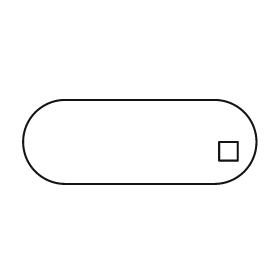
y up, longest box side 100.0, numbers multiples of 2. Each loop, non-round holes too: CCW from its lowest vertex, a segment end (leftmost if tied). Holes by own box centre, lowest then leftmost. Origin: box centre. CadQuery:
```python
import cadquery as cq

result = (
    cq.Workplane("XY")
    .moveTo(-32.0, -18.0)
    .lineTo(32.0, -18.0)
    .threePointArc((50.0, 0.0), (32.0, 18.0))
    .lineTo(-32.0, 18.0)
    .threePointArc((-50.0, 0.0), (-32.0, -18.0))
    .close()
    .moveTo(34.0, -8.0)
    .lineTo(42.0, -8.0)
    .lineTo(42.0, 0.0)
    .lineTo(34.0, 0.0)
    .close()
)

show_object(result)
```